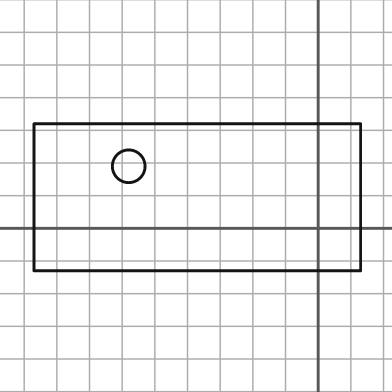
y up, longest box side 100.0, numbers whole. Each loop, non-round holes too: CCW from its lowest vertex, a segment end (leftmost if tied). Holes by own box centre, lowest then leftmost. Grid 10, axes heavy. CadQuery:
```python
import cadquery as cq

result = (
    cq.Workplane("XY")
    .moveTo(-87.0, -13.0)
    .lineTo(13.0, -13.0)
    .lineTo(13.0, 32.0)
    .lineTo(-87.0, 32.0)
    .close()
    .moveTo(-58.0, 19.0)
    .circle(5.0)
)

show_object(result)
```